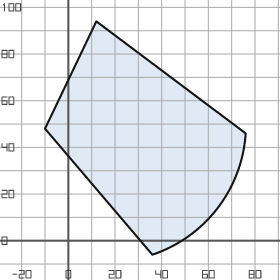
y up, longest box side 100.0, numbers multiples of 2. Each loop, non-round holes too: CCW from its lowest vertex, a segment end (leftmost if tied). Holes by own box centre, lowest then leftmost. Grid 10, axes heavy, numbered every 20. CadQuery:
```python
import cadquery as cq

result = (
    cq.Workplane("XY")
    .moveTo(36.0, -6.0)
    .threePointArc((64.0, 14.0), (76.0, 46.0))
    .lineTo(12.0, 94.0)
    .lineTo(-10.0, 48.0)
    .close()
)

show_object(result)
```